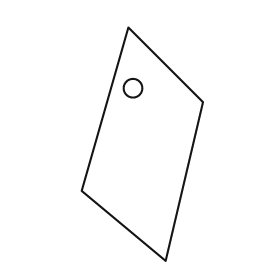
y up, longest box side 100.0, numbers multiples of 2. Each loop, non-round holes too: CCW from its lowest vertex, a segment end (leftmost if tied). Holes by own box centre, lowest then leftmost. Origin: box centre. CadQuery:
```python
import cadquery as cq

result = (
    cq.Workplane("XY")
    .moveTo(10.0, -50.0)
    .lineTo(26.0, 18.0)
    .lineTo(-6.0, 50.0)
    .lineTo(-26.0, -20.0)
    .close()
    .moveTo(-4.0, 24.0)
    .circle(4.0)
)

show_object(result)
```